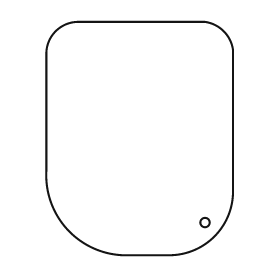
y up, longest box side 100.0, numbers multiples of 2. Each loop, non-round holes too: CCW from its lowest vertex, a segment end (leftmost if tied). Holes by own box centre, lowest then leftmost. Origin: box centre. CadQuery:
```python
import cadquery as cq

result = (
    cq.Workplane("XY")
    .moveTo(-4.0, -50.0)
    .lineTo(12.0, -50.0)
    .threePointArc((32.0, -42.0), (40.0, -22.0))
    .lineTo(40.0, 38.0)
    .threePointArc((36.0, 46.0), (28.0, 50.0))
    .lineTo(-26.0, 50.0)
    .threePointArc((-36.0, 46.0), (-40.0, 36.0))
    .lineTo(-40.0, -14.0)
    .threePointArc((-30.0, -40.0), (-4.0, -50.0))
    .close()
    .moveTo(28.0, -36.0)
    .circle(2.0)
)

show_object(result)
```